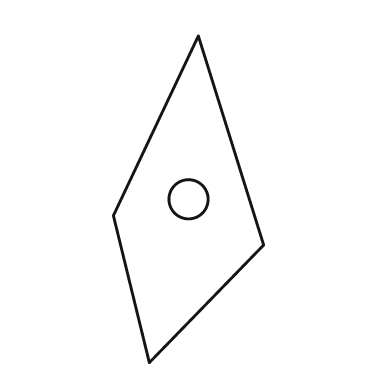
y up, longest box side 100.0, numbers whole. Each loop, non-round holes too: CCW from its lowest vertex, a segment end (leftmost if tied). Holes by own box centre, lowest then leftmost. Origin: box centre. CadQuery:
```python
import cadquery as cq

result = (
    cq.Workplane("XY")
    .moveTo(-12.0, -50.0)
    .lineTo(23.0, -14.0)
    .lineTo(3.0, 50.0)
    .lineTo(-23.0, -5.0)
    .close()
    .moveTo(0.0, 0.0)
    .circle(6.0)
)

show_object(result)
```